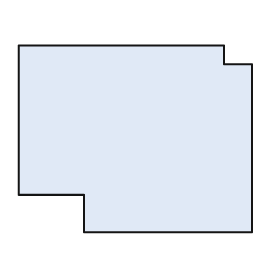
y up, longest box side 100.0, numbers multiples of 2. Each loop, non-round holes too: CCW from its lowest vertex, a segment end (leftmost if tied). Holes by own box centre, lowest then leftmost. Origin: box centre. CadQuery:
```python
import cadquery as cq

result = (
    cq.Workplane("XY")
    .moveTo(-22.0, -40.0)
    .lineTo(50.0, -40.0)
    .lineTo(50.0, 32.0)
    .lineTo(38.0, 32.0)
    .lineTo(38.0, 40.0)
    .lineTo(-50.0, 40.0)
    .lineTo(-50.0, -24.0)
    .lineTo(-22.0, -24.0)
    .close()
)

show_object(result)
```